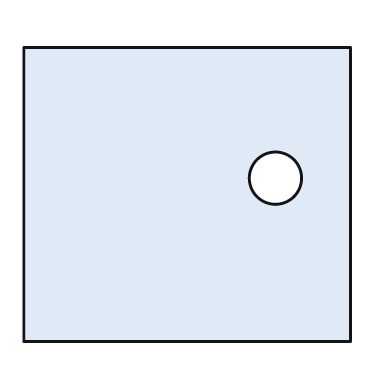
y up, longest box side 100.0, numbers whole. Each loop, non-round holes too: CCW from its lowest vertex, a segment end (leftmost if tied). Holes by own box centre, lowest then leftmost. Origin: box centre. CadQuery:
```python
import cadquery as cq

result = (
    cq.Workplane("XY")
    .moveTo(-50.0, -45.0)
    .lineTo(50.0, -45.0)
    .lineTo(50.0, 45.0)
    .lineTo(-50.0, 45.0)
    .close()
    .moveTo(27.0, 5.0)
    .circle(8.0)
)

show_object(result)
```